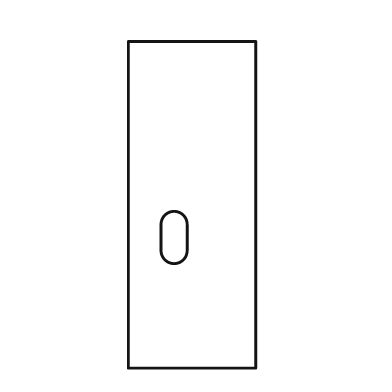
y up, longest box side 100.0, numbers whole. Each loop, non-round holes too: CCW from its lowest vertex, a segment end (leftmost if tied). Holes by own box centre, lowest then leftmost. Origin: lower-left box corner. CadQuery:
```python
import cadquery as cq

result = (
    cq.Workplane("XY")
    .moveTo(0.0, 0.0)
    .lineTo(39.0, 0.0)
    .lineTo(39.0, 100.0)
    .lineTo(0.0, 100.0)
    .close()
    .moveTo(10.0, 36.0)
    .threePointArc((14.0, 32.0), (18.0, 36.0))
    .lineTo(18.0, 44.0)
    .threePointArc((14.0, 48.0), (10.0, 44.0))
    .close()
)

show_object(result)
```